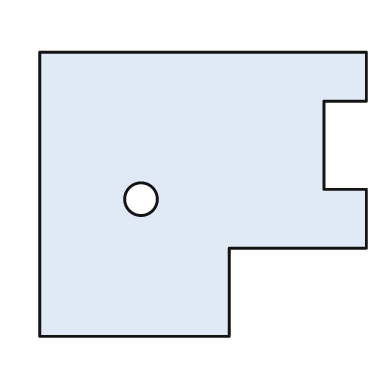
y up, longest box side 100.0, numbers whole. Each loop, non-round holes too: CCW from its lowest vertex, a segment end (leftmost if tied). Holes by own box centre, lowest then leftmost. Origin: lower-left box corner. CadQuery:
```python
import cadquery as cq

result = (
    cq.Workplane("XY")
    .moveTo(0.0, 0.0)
    .lineTo(58.0, 0.0)
    .lineTo(58.0, 27.0)
    .lineTo(100.0, 27.0)
    .lineTo(100.0, 45.0)
    .lineTo(87.0, 45.0)
    .lineTo(87.0, 72.0)
    .lineTo(100.0, 72.0)
    .lineTo(100.0, 87.0)
    .lineTo(0.0, 87.0)
    .close()
    .moveTo(31.0, 42.0)
    .circle(5.0)
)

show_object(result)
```